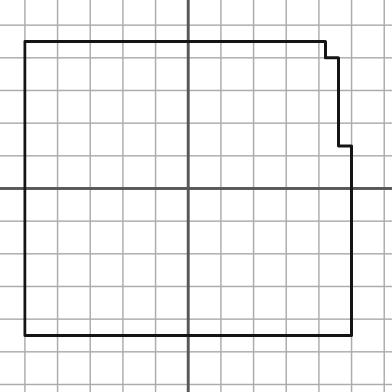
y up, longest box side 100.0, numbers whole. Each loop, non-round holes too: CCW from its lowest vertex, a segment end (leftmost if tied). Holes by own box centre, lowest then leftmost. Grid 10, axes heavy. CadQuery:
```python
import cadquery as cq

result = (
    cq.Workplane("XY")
    .moveTo(-50.0, -45.0)
    .lineTo(50.0, -45.0)
    .lineTo(50.0, 13.0)
    .lineTo(46.0, 13.0)
    .lineTo(46.0, 40.0)
    .lineTo(42.0, 40.0)
    .lineTo(42.0, 45.0)
    .lineTo(-50.0, 45.0)
    .close()
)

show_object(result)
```